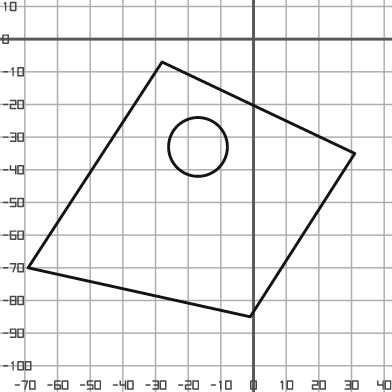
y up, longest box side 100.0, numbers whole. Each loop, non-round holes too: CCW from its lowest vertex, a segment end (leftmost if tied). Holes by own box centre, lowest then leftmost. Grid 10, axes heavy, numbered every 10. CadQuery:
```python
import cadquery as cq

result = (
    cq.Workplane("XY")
    .moveTo(-1.0, -85.0)
    .lineTo(31.0, -35.0)
    .lineTo(-28.0, -7.0)
    .lineTo(-69.0, -70.0)
    .close()
    .moveTo(-17.0, -33.0)
    .circle(9.0)
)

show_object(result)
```